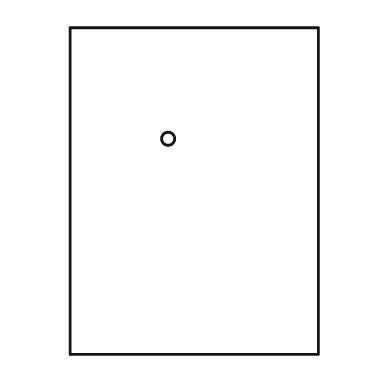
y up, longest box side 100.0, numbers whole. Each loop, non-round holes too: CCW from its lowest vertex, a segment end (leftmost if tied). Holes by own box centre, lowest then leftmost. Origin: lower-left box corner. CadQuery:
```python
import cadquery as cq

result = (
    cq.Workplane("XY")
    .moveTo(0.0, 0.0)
    .lineTo(76.0, 0.0)
    .lineTo(76.0, 100.0)
    .lineTo(0.0, 100.0)
    .close()
    .moveTo(30.0, 66.0)
    .circle(2.0)
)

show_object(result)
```